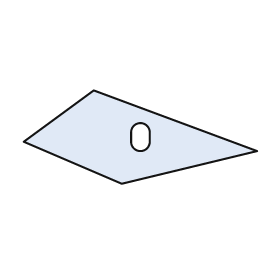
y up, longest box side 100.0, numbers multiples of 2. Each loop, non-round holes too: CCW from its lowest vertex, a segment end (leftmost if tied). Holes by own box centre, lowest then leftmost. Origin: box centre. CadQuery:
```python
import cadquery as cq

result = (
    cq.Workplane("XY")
    .moveTo(-8.0, -20.0)
    .lineTo(50.0, -6.0)
    .lineTo(-20.0, 20.0)
    .lineTo(-50.0, -2.0)
    .close()
    .moveTo(-4.0, -2.0)
    .threePointArc((0.0, -6.0), (4.0, -2.0))
    .lineTo(4.0, 2.0)
    .threePointArc((0.0, 6.0), (-4.0, 2.0))
    .close()
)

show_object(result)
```